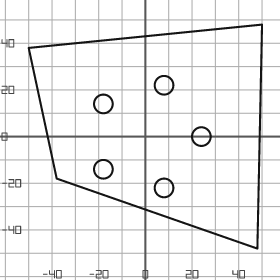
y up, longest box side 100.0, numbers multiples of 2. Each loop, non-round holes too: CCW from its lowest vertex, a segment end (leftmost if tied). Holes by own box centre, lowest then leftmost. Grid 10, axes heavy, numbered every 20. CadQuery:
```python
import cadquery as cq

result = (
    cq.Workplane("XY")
    .moveTo(48.0, -48.0)
    .lineTo(50.0, 48.0)
    .lineTo(-50.0, 38.0)
    .lineTo(-38.0, -18.0)
    .close()
    .moveTo(8.0, -22.0)
    .circle(4.0)
    .moveTo(-18.0, -14.0)
    .circle(4.0)
    .moveTo(24.0, 0.0)
    .circle(4.0)
    .moveTo(-18.0, 14.0)
    .circle(4.0)
    .moveTo(8.0, 22.0)
    .circle(4.0)
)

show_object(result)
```